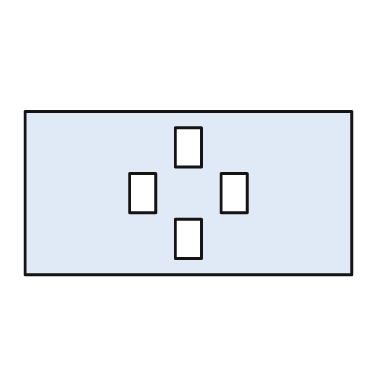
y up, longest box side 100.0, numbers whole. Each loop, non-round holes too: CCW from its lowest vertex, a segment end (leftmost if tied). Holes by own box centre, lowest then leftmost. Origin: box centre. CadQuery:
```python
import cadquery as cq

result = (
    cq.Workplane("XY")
    .moveTo(-50.0, -25.0)
    .lineTo(50.0, -25.0)
    .lineTo(50.0, 25.0)
    .lineTo(-50.0, 25.0)
    .close()
    .moveTo(-4.0, -20.0)
    .lineTo(4.0, -20.0)
    .lineTo(4.0, -8.0)
    .lineTo(-4.0, -8.0)
    .close()
    .moveTo(-18.0, -6.0)
    .lineTo(-10.0, -6.0)
    .lineTo(-10.0, 6.0)
    .lineTo(-18.0, 6.0)
    .close()
    .moveTo(10.0, -6.0)
    .lineTo(18.0, -6.0)
    .lineTo(18.0, 6.0)
    .lineTo(10.0, 6.0)
    .close()
    .moveTo(-4.0, 8.0)
    .lineTo(4.0, 8.0)
    .lineTo(4.0, 20.0)
    .lineTo(-4.0, 20.0)
    .close()
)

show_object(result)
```